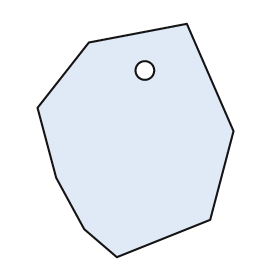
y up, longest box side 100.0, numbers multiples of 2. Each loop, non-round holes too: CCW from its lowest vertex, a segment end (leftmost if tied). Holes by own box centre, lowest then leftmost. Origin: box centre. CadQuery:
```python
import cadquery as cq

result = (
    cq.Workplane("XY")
    .moveTo(-8.0, -50.0)
    .lineTo(32.0, -34.0)
    .lineTo(42.0, 4.0)
    .lineTo(22.0, 50.0)
    .lineTo(-20.0, 42.0)
    .lineTo(-42.0, 14.0)
    .lineTo(-34.0, -16.0)
    .lineTo(-22.0, -38.0)
    .close()
    .moveTo(4.0, 30.0)
    .circle(4.0)
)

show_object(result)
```